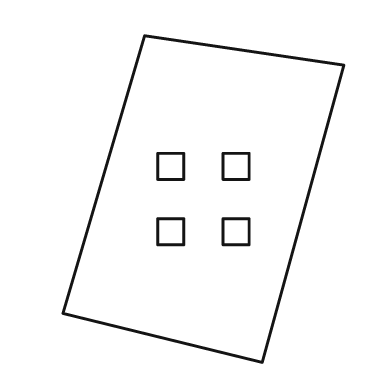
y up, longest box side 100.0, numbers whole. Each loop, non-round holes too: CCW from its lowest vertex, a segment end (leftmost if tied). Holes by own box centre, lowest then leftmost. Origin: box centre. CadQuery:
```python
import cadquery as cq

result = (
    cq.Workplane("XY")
    .moveTo(18.0, -50.0)
    .lineTo(43.0, 41.0)
    .lineTo(-18.0, 50.0)
    .lineTo(-43.0, -35.0)
    .close()
    .moveTo(-14.0, -14.0)
    .lineTo(-6.0, -14.0)
    .lineTo(-6.0, -6.0)
    .lineTo(-14.0, -6.0)
    .close()
    .moveTo(6.0, -14.0)
    .lineTo(14.0, -14.0)
    .lineTo(14.0, -6.0)
    .lineTo(6.0, -6.0)
    .close()
    .moveTo(-14.0, 6.0)
    .lineTo(-6.0, 6.0)
    .lineTo(-6.0, 14.0)
    .lineTo(-14.0, 14.0)
    .close()
    .moveTo(6.0, 6.0)
    .lineTo(14.0, 6.0)
    .lineTo(14.0, 14.0)
    .lineTo(6.0, 14.0)
    .close()
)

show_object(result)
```